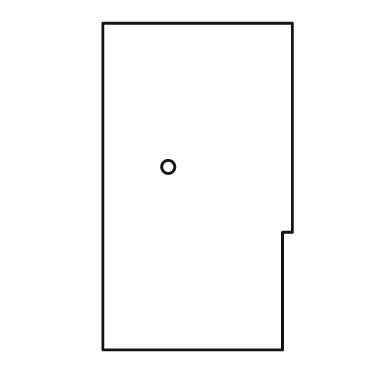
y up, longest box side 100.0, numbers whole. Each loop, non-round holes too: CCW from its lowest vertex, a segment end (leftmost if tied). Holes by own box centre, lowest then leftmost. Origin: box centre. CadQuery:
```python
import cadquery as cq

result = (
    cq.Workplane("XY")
    .moveTo(-29.0, -50.0)
    .lineTo(26.0, -50.0)
    .lineTo(26.0, -14.0)
    .lineTo(29.0, -14.0)
    .lineTo(29.0, 50.0)
    .lineTo(-29.0, 50.0)
    .close()
    .moveTo(-9.0, 6.0)
    .circle(2.0)
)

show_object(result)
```